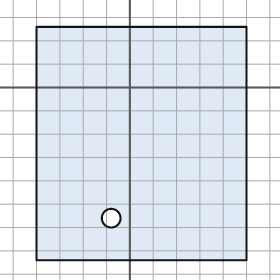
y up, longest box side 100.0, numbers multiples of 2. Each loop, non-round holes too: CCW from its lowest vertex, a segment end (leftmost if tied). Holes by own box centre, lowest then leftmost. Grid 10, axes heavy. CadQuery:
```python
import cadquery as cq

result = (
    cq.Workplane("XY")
    .moveTo(-40.0, -74.0)
    .lineTo(50.0, -74.0)
    .lineTo(50.0, 26.0)
    .lineTo(-40.0, 26.0)
    .close()
    .moveTo(-8.0, -56.0)
    .circle(4.0)
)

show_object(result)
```